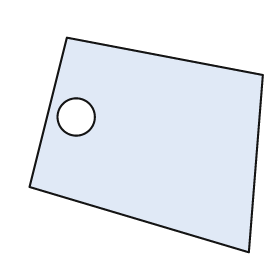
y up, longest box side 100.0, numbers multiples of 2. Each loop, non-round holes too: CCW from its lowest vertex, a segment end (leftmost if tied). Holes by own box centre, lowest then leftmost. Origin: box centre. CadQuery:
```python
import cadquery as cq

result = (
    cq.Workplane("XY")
    .moveTo(44.0, -46.0)
    .lineTo(50.0, 30.0)
    .lineTo(-34.0, 46.0)
    .lineTo(-50.0, -18.0)
    .close()
    .moveTo(-30.0, 12.0)
    .circle(8.0)
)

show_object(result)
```